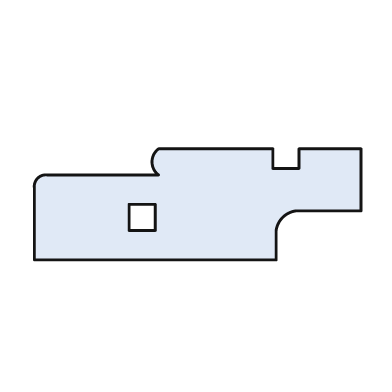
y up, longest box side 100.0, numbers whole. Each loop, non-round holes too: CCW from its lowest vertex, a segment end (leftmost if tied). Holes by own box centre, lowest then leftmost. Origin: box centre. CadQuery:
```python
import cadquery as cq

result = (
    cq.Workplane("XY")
    .moveTo(-50.0, -17.0)
    .lineTo(24.0, -17.0)
    .lineTo(24.0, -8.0)
    .threePointArc((26.0, -4.0), (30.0, -2.0))
    .lineTo(50.0, -2.0)
    .lineTo(50.0, 17.0)
    .lineTo(31.0, 17.0)
    .lineTo(31.0, 11.0)
    .lineTo(23.0, 11.0)
    .lineTo(23.0, 17.0)
    .lineTo(-12.0, 17.0)
    .threePointArc((-14.0, 13.0), (-12.0, 9.0))
    .lineTo(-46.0, 9.0)
    .threePointArc((-49.0, 8.0), (-50.0, 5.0))
    .close()
    .moveTo(-21.0, -8.0)
    .lineTo(-13.0, -8.0)
    .lineTo(-13.0, 0.0)
    .lineTo(-21.0, 0.0)
    .close()
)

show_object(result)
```